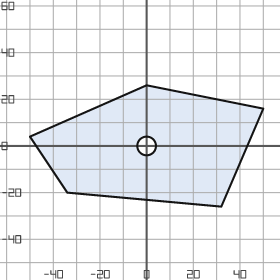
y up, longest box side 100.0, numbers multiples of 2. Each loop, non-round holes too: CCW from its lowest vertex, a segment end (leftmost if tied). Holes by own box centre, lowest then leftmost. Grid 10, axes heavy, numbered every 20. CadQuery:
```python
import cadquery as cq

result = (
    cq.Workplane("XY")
    .moveTo(32.0, -26.0)
    .lineTo(50.0, 16.0)
    .lineTo(0.0, 26.0)
    .lineTo(-50.0, 4.0)
    .lineTo(-34.0, -20.0)
    .close()
    .moveTo(0.0, 0.0)
    .circle(4.0)
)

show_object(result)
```